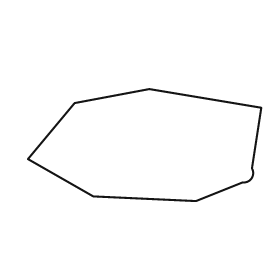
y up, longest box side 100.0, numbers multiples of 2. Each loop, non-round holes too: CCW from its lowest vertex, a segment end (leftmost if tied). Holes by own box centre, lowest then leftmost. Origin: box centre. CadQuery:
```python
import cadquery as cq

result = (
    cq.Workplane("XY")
    .moveTo(22.0, -24.0)
    .lineTo(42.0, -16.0)
    .threePointArc((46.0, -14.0), (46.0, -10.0))
    .lineTo(50.0, 16.0)
    .lineTo(2.0, 24.0)
    .lineTo(-30.0, 18.0)
    .lineTo(-50.0, -6.0)
    .lineTo(-22.0, -22.0)
    .close()
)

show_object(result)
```